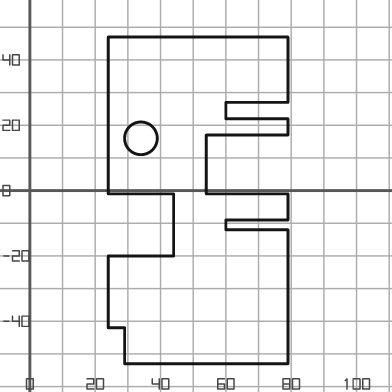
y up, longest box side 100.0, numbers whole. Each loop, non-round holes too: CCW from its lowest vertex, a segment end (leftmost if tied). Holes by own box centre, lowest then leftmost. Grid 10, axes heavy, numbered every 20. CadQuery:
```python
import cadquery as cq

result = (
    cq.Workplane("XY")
    .moveTo(29.0, -53.0)
    .lineTo(79.0, -53.0)
    .lineTo(79.0, -12.0)
    .lineTo(60.0, -12.0)
    .lineTo(60.0, -9.0)
    .lineTo(79.0, -9.0)
    .lineTo(79.0, -1.0)
    .lineTo(54.0, -1.0)
    .lineTo(54.0, 17.0)
    .lineTo(79.0, 17.0)
    .lineTo(79.0, 22.0)
    .lineTo(60.0, 22.0)
    .lineTo(60.0, 27.0)
    .lineTo(79.0, 27.0)
    .lineTo(79.0, 47.0)
    .lineTo(24.0, 47.0)
    .lineTo(24.0, -1.0)
    .lineTo(44.0, -1.0)
    .lineTo(44.0, -20.0)
    .lineTo(24.0, -20.0)
    .lineTo(24.0, -42.0)
    .lineTo(29.0, -42.0)
    .close()
    .moveTo(34.0, 16.0)
    .circle(5.0)
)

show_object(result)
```